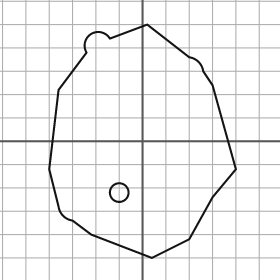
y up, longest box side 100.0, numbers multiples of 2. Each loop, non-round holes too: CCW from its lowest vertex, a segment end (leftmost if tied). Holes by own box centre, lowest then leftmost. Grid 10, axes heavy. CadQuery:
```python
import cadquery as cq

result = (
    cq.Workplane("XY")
    .moveTo(4.0, -50.0)
    .lineTo(20.0, -42.0)
    .lineTo(30.0, -24.0)
    .lineTo(40.0, -12.0)
    .lineTo(30.0, 24.0)
    .lineTo(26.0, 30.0)
    .threePointArc((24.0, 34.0), (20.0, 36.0))
    .lineTo(2.0, 50.0)
    .lineTo(-14.0, 44.0)
    .threePointArc((-22.0, 46.0), (-24.0, 38.0))
    .lineTo(-36.0, 22.0)
    .lineTo(-40.0, -12.0)
    .lineTo(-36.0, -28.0)
    .threePointArc((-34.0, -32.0), (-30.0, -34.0))
    .lineTo(-22.0, -40.0)
    .close()
    .moveTo(-10.0, -22.0)
    .circle(4.0)
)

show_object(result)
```